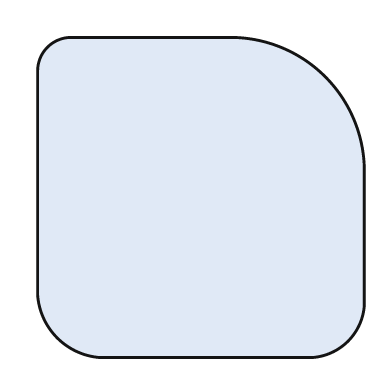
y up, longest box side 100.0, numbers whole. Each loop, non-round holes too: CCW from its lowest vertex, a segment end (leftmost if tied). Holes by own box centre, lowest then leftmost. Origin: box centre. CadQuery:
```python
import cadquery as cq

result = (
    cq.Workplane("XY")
    .moveTo(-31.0, -49.0)
    .lineTo(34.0, -49.0)
    .threePointArc((45.0, -44.0), (50.0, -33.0))
    .lineTo(50.0, 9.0)
    .threePointArc((38.0, 37.0), (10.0, 49.0))
    .lineTo(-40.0, 49.0)
    .threePointArc((-47.0, 46.0), (-50.0, 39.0))
    .lineTo(-50.0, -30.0)
    .threePointArc((-44.0, -43.0), (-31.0, -49.0))
    .close()
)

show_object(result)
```